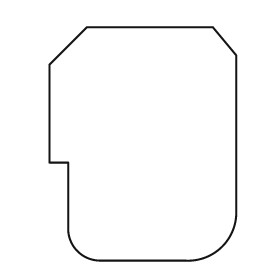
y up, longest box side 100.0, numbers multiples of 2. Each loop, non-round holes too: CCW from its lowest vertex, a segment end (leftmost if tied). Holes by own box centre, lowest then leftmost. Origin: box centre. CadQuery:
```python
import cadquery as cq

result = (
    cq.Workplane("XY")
    .moveTo(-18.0, -50.0)
    .lineTo(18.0, -50.0)
    .threePointArc((34.0, -44.0), (40.0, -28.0))
    .lineTo(40.0, 38.0)
    .lineTo(30.0, 50.0)
    .lineTo(-24.0, 50.0)
    .lineTo(-40.0, 34.0)
    .lineTo(-40.0, -8.0)
    .lineTo(-32.0, -8.0)
    .lineTo(-32.0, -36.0)
    .threePointArc((-28.0, -46.0), (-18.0, -50.0))
    .close()
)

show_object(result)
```